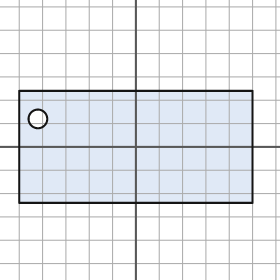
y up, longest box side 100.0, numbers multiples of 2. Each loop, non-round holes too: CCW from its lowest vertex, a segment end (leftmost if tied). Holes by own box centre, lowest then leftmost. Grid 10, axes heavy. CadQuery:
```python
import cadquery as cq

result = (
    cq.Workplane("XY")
    .moveTo(-50.0, -24.0)
    .lineTo(50.0, -24.0)
    .lineTo(50.0, 24.0)
    .lineTo(-50.0, 24.0)
    .close()
    .moveTo(-42.0, 12.0)
    .circle(4.0)
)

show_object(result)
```